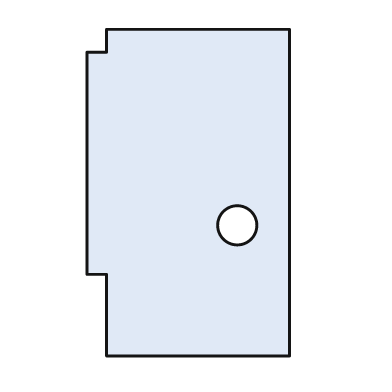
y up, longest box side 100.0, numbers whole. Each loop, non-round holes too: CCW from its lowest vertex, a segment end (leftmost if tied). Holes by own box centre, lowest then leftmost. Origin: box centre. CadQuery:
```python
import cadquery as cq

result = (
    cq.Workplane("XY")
    .moveTo(-25.0, -50.0)
    .lineTo(31.0, -50.0)
    .lineTo(31.0, 50.0)
    .lineTo(-25.0, 50.0)
    .lineTo(-25.0, 43.0)
    .lineTo(-31.0, 43.0)
    .lineTo(-31.0, -25.0)
    .lineTo(-25.0, -25.0)
    .close()
    .moveTo(15.0, -10.0)
    .circle(6.0)
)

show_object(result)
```